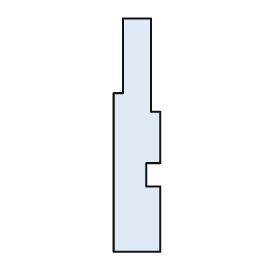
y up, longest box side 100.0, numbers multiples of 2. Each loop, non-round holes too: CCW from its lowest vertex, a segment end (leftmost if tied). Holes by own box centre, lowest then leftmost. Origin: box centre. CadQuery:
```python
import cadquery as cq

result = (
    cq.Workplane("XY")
    .moveTo(-10.0, -50.0)
    .lineTo(10.0, -50.0)
    .lineTo(10.0, -22.0)
    .lineTo(4.0, -22.0)
    .lineTo(4.0, -12.0)
    .lineTo(10.0, -12.0)
    .lineTo(10.0, 10.0)
    .lineTo(6.0, 10.0)
    .lineTo(6.0, 50.0)
    .lineTo(-6.0, 50.0)
    .lineTo(-6.0, 18.0)
    .lineTo(-10.0, 18.0)
    .close()
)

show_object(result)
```